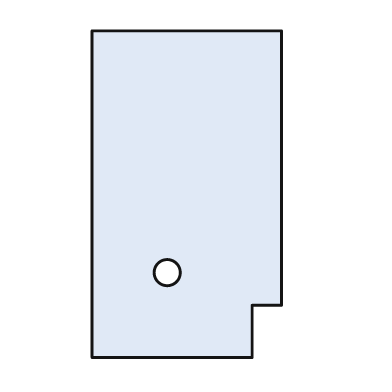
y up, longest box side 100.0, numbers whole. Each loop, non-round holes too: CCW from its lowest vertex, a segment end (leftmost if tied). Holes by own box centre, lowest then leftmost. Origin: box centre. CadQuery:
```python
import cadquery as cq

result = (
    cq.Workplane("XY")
    .moveTo(-29.0, -50.0)
    .lineTo(20.0, -50.0)
    .lineTo(20.0, -34.0)
    .lineTo(29.0, -34.0)
    .lineTo(29.0, 50.0)
    .lineTo(-29.0, 50.0)
    .close()
    .moveTo(-6.0, -24.0)
    .circle(4.0)
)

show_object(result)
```